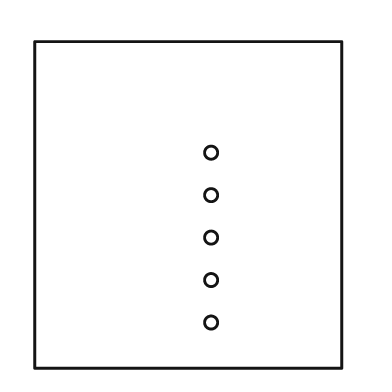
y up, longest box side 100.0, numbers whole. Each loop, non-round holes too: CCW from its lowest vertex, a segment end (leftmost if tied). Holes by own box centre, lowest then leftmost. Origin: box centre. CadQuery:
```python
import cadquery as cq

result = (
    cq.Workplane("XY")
    .moveTo(-47.0, -50.0)
    .lineTo(47.0, -50.0)
    .lineTo(47.0, 50.0)
    .lineTo(-47.0, 50.0)
    .close()
    .moveTo(7.0, -36.0)
    .circle(2.0)
    .moveTo(7.0, -23.0)
    .circle(2.0)
    .moveTo(7.0, -10.0)
    .circle(2.0)
    .moveTo(7.0, 3.0)
    .circle(2.0)
    .moveTo(7.0, 16.0)
    .circle(2.0)
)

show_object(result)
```